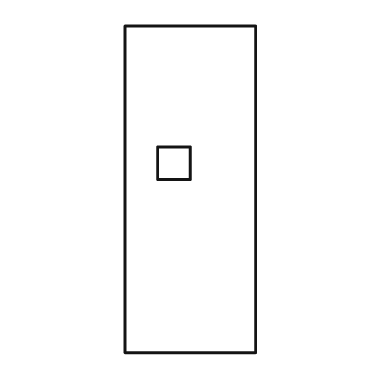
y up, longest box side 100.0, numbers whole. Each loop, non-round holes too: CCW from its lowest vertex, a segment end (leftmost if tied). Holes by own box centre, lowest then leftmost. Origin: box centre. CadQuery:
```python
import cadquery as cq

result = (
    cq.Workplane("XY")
    .moveTo(-20.0, -50.0)
    .lineTo(20.0, -50.0)
    .lineTo(20.0, 50.0)
    .lineTo(-20.0, 50.0)
    .close()
    .moveTo(-10.0, 3.0)
    .lineTo(0.0, 3.0)
    .lineTo(0.0, 13.0)
    .lineTo(-10.0, 13.0)
    .close()
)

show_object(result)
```